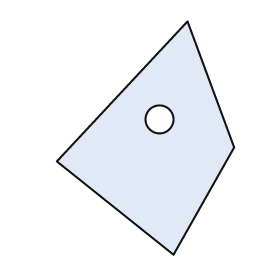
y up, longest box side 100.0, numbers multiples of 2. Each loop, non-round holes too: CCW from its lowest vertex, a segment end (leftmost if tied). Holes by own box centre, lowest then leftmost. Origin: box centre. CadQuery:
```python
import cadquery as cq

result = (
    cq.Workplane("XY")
    .moveTo(12.0, -50.0)
    .lineTo(38.0, -4.0)
    .lineTo(18.0, 50.0)
    .lineTo(-38.0, -10.0)
    .close()
    .moveTo(6.0, 8.0)
    .circle(6.0)
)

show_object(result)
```